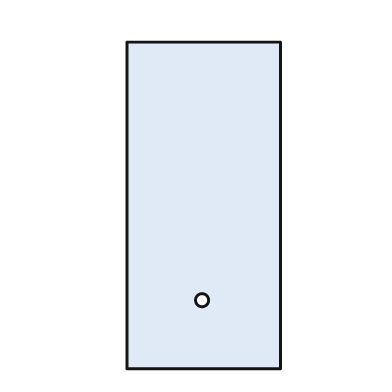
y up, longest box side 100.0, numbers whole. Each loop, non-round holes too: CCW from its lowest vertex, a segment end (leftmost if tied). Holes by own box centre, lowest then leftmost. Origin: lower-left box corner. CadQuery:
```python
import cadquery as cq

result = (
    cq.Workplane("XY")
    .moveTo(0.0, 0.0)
    .lineTo(47.0, 0.0)
    .lineTo(47.0, 100.0)
    .lineTo(0.0, 100.0)
    .close()
    .moveTo(23.0, 21.0)
    .circle(2.0)
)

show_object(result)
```